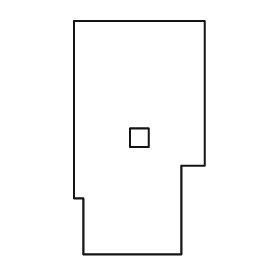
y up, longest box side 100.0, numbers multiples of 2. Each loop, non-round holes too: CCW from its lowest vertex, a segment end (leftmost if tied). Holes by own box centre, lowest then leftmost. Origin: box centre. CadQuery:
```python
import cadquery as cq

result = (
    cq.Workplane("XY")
    .moveTo(-24.0, -50.0)
    .lineTo(18.0, -50.0)
    .lineTo(18.0, -12.0)
    .lineTo(28.0, -12.0)
    .lineTo(28.0, 50.0)
    .lineTo(-28.0, 50.0)
    .lineTo(-28.0, -26.0)
    .lineTo(-24.0, -26.0)
    .close()
    .moveTo(-4.0, -4.0)
    .lineTo(4.0, -4.0)
    .lineTo(4.0, 4.0)
    .lineTo(-4.0, 4.0)
    .close()
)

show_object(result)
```